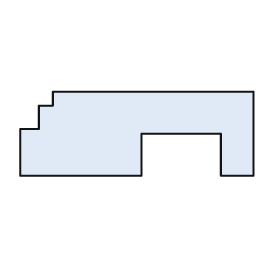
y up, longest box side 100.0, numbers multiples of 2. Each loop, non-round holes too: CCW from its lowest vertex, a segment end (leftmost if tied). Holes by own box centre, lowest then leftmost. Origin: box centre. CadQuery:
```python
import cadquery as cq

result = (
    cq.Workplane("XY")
    .moveTo(-50.0, -18.0)
    .lineTo(2.0, -18.0)
    .lineTo(2.0, 0.0)
    .lineTo(36.0, 0.0)
    .lineTo(36.0, -18.0)
    .lineTo(50.0, -18.0)
    .lineTo(50.0, 18.0)
    .lineTo(-36.0, 18.0)
    .lineTo(-36.0, 12.0)
    .lineTo(-42.0, 12.0)
    .lineTo(-42.0, 2.0)
    .lineTo(-50.0, 2.0)
    .close()
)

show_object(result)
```